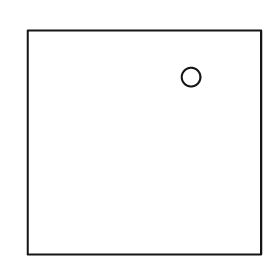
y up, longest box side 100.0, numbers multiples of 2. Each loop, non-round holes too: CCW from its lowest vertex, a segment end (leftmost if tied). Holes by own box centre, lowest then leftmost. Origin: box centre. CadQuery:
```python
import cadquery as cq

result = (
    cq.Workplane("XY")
    .moveTo(-50.0, -48.0)
    .lineTo(50.0, -48.0)
    .lineTo(50.0, 48.0)
    .lineTo(-50.0, 48.0)
    .close()
    .moveTo(20.0, 28.0)
    .circle(4.0)
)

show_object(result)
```